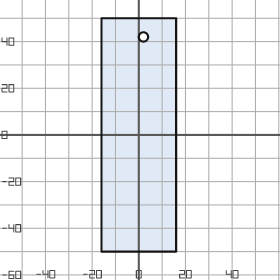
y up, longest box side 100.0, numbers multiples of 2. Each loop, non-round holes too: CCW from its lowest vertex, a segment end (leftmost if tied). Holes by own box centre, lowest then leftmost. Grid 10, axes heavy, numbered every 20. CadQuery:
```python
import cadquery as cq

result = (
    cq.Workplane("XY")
    .moveTo(-16.0, -50.0)
    .lineTo(16.0, -50.0)
    .lineTo(16.0, 50.0)
    .lineTo(-16.0, 50.0)
    .close()
    .moveTo(2.0, 42.0)
    .circle(2.0)
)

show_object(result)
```